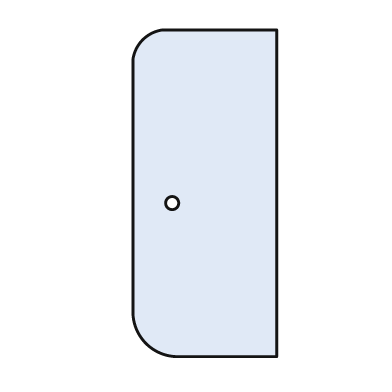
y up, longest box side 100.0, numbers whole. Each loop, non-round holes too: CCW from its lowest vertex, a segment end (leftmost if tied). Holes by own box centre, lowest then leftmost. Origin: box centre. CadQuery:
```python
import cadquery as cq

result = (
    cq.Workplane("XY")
    .moveTo(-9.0, -50.0)
    .lineTo(22.0, -50.0)
    .lineTo(22.0, 50.0)
    .lineTo(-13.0, 50.0)
    .threePointArc((-19.0, 47.0), (-22.0, 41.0))
    .lineTo(-22.0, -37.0)
    .threePointArc((-18.0, -46.0), (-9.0, -50.0))
    .close()
    .moveTo(-10.0, -3.0)
    .circle(2.0)
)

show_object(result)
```